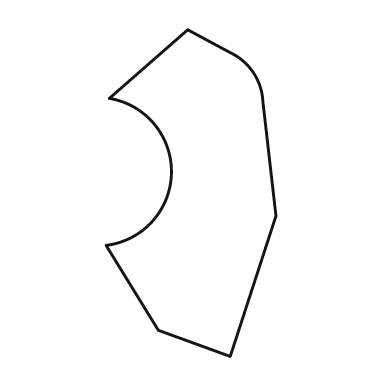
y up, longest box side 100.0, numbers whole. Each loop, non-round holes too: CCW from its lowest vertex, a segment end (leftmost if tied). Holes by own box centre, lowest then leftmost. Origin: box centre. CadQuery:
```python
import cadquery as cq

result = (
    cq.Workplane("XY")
    .moveTo(12.0, -50.0)
    .lineTo(26.0, -7.0)
    .lineTo(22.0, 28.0)
    .threePointArc((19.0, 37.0), (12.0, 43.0))
    .lineTo(-1.0, 50.0)
    .lineTo(-25.0, 29.0)
    .threePointArc((-6.0, 6.0), (-26.0, -16.0))
    .lineTo(-10.0, -42.0)
    .close()
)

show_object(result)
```